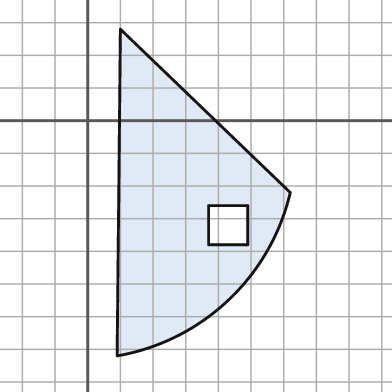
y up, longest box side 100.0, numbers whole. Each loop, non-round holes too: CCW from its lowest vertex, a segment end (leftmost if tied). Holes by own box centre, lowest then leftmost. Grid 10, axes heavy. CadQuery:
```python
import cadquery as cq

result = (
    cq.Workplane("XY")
    .moveTo(9.0, -72.0)
    .threePointArc((43.0, -55.0), (62.0, -22.0))
    .lineTo(10.0, 28.0)
    .close()
    .moveTo(37.0, -38.0)
    .lineTo(49.0, -38.0)
    .lineTo(49.0, -26.0)
    .lineTo(37.0, -26.0)
    .close()
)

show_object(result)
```